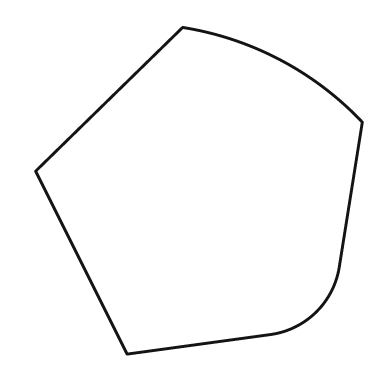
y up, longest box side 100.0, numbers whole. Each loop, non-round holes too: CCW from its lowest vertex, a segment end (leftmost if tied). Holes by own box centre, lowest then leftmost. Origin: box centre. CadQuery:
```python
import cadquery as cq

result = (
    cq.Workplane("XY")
    .moveTo(-22.0, -50.0)
    .lineTo(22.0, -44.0)
    .threePointArc((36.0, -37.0), (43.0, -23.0))
    .lineTo(50.0, 21.0)
    .threePointArc((25.0, 40.0), (-5.0, 50.0))
    .lineTo(-50.0, 6.0)
    .close()
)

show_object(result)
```